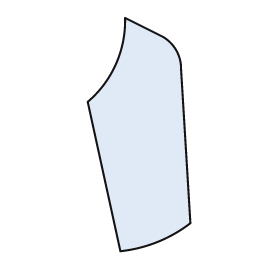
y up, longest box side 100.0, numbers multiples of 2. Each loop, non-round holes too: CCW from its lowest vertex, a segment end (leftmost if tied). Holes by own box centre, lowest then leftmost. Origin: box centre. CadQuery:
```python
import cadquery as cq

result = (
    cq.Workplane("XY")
    .moveTo(-8.0, -50.0)
    .threePointArc((8.0, -46.0), (22.0, -38.0))
    .lineTo(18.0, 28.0)
    .threePointArc((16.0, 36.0), (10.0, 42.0))
    .lineTo(-6.0, 50.0)
    .threePointArc((-10.0, 30.0), (-22.0, 14.0))
    .close()
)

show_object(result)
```